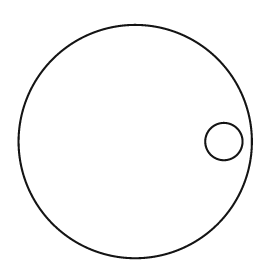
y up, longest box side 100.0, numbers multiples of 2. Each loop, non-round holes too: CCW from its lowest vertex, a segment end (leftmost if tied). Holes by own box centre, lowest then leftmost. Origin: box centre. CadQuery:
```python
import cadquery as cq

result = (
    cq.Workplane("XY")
    .moveTo(0.0, 0.0)
    .circle(50.0)
    .moveTo(38.0, 0.0)
    .circle(8.0)
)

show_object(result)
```